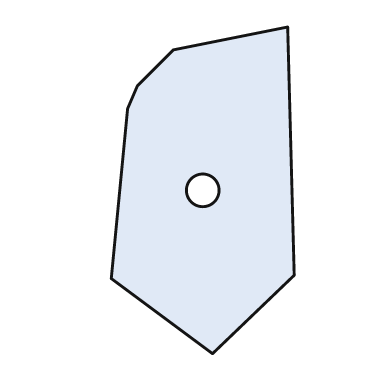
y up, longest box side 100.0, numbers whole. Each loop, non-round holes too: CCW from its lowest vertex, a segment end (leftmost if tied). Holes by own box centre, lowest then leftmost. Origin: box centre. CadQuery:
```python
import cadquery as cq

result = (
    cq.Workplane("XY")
    .moveTo(3.0, -50.0)
    .lineTo(28.0, -26.0)
    .lineTo(26.0, 50.0)
    .lineTo(-9.0, 43.0)
    .lineTo(-20.0, 32.0)
    .lineTo(-23.0, 25.0)
    .lineTo(-28.0, -27.0)
    .close()
    .moveTo(0.0, 0.0)
    .circle(5.0)
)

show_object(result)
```